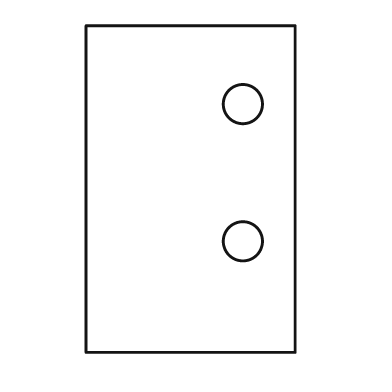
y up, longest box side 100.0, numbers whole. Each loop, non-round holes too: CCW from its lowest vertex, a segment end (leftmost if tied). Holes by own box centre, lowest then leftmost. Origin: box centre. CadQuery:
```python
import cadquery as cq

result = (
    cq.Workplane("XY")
    .moveTo(-32.0, -50.0)
    .lineTo(32.0, -50.0)
    .lineTo(32.0, 50.0)
    .lineTo(-32.0, 50.0)
    .close()
    .moveTo(16.0, -16.0)
    .circle(6.0)
    .moveTo(16.0, 26.0)
    .circle(6.0)
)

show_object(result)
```